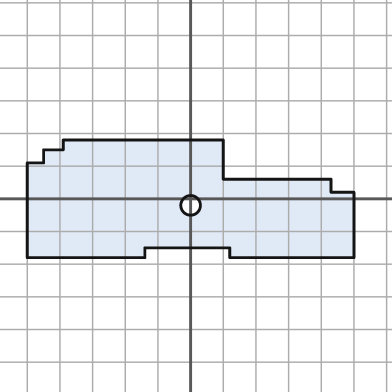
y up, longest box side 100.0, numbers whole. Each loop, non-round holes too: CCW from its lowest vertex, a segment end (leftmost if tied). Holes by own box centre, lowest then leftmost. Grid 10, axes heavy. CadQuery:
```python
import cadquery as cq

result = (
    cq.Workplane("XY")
    .moveTo(-50.0, -18.0)
    .lineTo(-14.0, -18.0)
    .lineTo(-14.0, -15.0)
    .lineTo(12.0, -15.0)
    .lineTo(12.0, -18.0)
    .lineTo(50.0, -18.0)
    .lineTo(50.0, 2.0)
    .lineTo(43.0, 2.0)
    .lineTo(43.0, 6.0)
    .lineTo(10.0, 6.0)
    .lineTo(10.0, 18.0)
    .lineTo(-39.0, 18.0)
    .lineTo(-39.0, 15.0)
    .lineTo(-45.0, 15.0)
    .lineTo(-45.0, 11.0)
    .lineTo(-50.0, 11.0)
    .close()
    .moveTo(0.0, -2.0)
    .circle(3.0)
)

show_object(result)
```